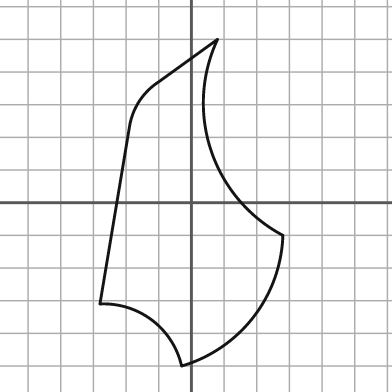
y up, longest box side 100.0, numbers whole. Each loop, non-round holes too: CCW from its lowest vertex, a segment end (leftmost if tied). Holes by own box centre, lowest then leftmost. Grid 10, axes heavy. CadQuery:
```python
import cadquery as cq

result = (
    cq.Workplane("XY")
    .moveTo(-3.0, -50.0)
    .threePointArc((19.0, -35.0), (28.0, -10.0))
    .threePointArc((6.0, 16.0), (8.0, 50.0))
    .lineTo(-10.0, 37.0)
    .threePointArc((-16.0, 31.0), (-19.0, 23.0))
    .lineTo(-28.0, -31.0)
    .threePointArc((-12.0, -36.0), (-3.0, -50.0))
    .close()
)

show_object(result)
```